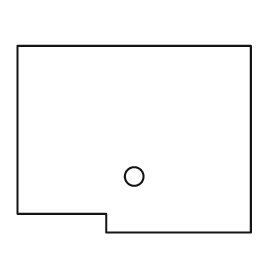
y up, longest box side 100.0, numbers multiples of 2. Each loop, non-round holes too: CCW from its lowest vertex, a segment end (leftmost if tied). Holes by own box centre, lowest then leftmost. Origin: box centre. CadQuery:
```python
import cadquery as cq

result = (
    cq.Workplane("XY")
    .moveTo(-12.0, -40.0)
    .lineTo(50.0, -40.0)
    .lineTo(50.0, 40.0)
    .lineTo(-50.0, 40.0)
    .lineTo(-50.0, -32.0)
    .lineTo(-12.0, -32.0)
    .close()
    .moveTo(0.0, -16.0)
    .circle(4.0)
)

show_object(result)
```